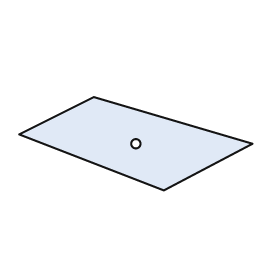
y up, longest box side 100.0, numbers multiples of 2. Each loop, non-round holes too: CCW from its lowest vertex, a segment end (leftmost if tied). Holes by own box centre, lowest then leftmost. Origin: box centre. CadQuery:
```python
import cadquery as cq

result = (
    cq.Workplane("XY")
    .moveTo(12.0, -20.0)
    .lineTo(50.0, 0.0)
    .lineTo(-18.0, 20.0)
    .lineTo(-50.0, 4.0)
    .close()
    .moveTo(0.0, 0.0)
    .circle(2.0)
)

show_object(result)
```